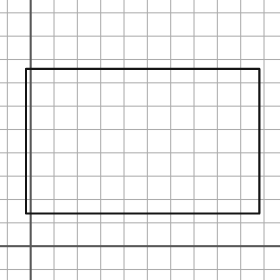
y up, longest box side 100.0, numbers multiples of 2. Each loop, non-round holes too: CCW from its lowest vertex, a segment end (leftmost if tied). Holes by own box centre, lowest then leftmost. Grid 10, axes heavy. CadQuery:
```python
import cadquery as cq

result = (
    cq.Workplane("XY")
    .moveTo(-2.0, 14.0)
    .lineTo(98.0, 14.0)
    .lineTo(98.0, 76.0)
    .lineTo(-2.0, 76.0)
    .close()
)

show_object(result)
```